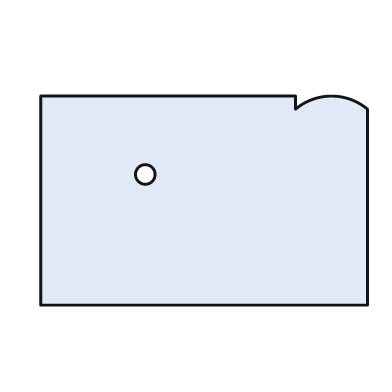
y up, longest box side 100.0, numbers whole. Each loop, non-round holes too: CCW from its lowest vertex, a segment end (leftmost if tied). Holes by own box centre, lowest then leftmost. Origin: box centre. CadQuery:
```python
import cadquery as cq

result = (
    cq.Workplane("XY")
    .moveTo(-50.0, -32.0)
    .lineTo(50.0, -32.0)
    .lineTo(50.0, 28.0)
    .threePointArc((39.0, 32.0), (28.0, 28.0))
    .lineTo(28.0, 32.0)
    .lineTo(-50.0, 32.0)
    .close()
    .moveTo(-18.0, 8.0)
    .circle(3.0)
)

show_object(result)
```